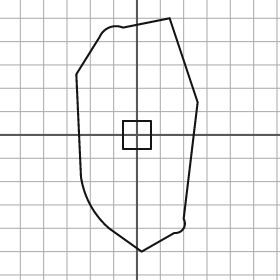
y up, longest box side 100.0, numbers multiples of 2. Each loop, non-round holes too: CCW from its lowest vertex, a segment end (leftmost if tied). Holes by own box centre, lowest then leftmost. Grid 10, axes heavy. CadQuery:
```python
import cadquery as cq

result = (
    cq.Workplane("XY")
    .moveTo(2.0, -50.0)
    .lineTo(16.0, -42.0)
    .threePointArc((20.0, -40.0), (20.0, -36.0))
    .lineTo(26.0, 14.0)
    .lineTo(14.0, 50.0)
    .lineTo(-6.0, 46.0)
    .threePointArc((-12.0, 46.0), (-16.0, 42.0))
    .lineTo(-26.0, 26.0)
    .lineTo(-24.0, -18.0)
    .threePointArc((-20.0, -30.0), (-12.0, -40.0))
    .close()
    .moveTo(-6.0, -6.0)
    .lineTo(6.0, -6.0)
    .lineTo(6.0, 6.0)
    .lineTo(-6.0, 6.0)
    .close()
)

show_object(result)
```